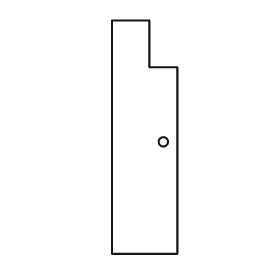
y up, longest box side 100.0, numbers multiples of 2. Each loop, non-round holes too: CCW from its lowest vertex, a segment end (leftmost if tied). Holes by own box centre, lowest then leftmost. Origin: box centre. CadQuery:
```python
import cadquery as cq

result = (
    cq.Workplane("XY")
    .moveTo(-14.0, -50.0)
    .lineTo(14.0, -50.0)
    .lineTo(14.0, 30.0)
    .lineTo(2.0, 30.0)
    .lineTo(2.0, 50.0)
    .lineTo(-14.0, 50.0)
    .close()
    .moveTo(8.0, -2.0)
    .circle(2.0)
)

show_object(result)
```